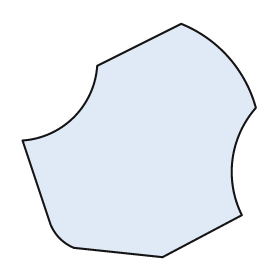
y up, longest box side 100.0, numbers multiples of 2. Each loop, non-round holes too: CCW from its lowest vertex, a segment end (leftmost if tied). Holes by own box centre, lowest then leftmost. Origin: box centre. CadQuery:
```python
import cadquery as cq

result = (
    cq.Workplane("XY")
    .moveTo(10.0, -50.0)
    .lineTo(44.0, -32.0)
    .threePointArc((40.0, -8.0), (50.0, 14.0))
    .threePointArc((38.0, 36.0), (18.0, 50.0))
    .lineTo(-18.0, 32.0)
    .threePointArc((-28.0, 10.0), (-50.0, 0.0))
    .lineTo(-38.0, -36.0)
    .threePointArc((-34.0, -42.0), (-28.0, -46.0))
    .close()
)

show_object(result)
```